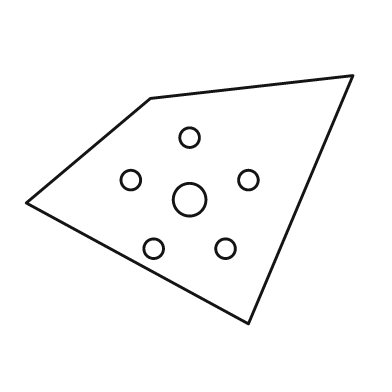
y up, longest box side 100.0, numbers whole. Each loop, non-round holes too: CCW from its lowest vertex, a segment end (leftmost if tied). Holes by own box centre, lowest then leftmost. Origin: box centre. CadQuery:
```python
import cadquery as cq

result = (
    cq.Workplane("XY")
    .moveTo(18.0, -38.0)
    .lineTo(50.0, 38.0)
    .lineTo(-12.0, 31.0)
    .lineTo(-50.0, -1.0)
    .close()
    .moveTo(-11.0, -15.0)
    .circle(3.0)
    .moveTo(11.0, -15.0)
    .circle(3.0)
    .moveTo(0.0, 0.0)
    .circle(5.0)
    .moveTo(-18.0, 6.0)
    .circle(3.0)
    .moveTo(18.0, 6.0)
    .circle(3.0)
    .moveTo(0.0, 19.0)
    .circle(3.0)
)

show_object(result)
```